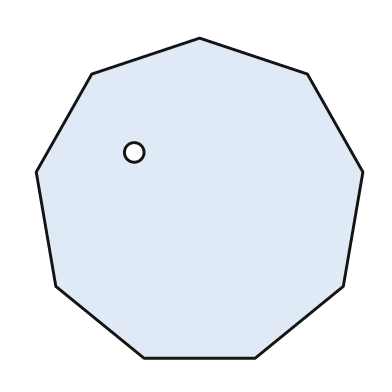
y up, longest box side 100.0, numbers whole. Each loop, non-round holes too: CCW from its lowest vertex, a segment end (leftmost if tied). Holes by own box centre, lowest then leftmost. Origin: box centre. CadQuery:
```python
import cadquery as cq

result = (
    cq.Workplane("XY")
    .moveTo(-17.0, -49.0)
    .lineTo(17.0, -49.0)
    .lineTo(44.0, -27.0)
    .lineTo(50.0, 8.0)
    .lineTo(33.0, 38.0)
    .lineTo(0.0, 49.0)
    .lineTo(-33.0, 38.0)
    .lineTo(-50.0, 8.0)
    .lineTo(-44.0, -27.0)
    .close()
    .moveTo(-20.0, 14.0)
    .circle(3.0)
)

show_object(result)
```